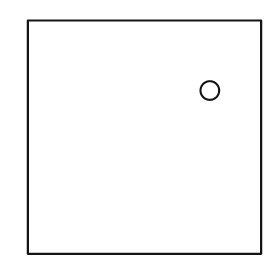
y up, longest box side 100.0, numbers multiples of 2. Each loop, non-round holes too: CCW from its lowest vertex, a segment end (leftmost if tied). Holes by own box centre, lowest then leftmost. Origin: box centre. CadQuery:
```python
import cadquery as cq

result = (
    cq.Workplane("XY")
    .moveTo(-50.0, -50.0)
    .lineTo(50.0, -50.0)
    .lineTo(50.0, 50.0)
    .lineTo(-50.0, 50.0)
    .close()
    .moveTo(28.0, 20.0)
    .circle(4.0)
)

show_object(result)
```